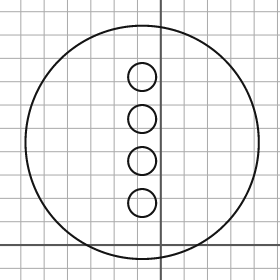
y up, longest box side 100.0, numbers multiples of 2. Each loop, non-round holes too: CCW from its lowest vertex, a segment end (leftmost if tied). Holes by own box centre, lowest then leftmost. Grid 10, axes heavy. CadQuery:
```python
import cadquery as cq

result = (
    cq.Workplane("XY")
    .moveTo(-8.0, 44.0)
    .circle(50.0)
    .moveTo(-8.0, 18.0)
    .circle(6.0)
    .moveTo(-8.0, 36.0)
    .circle(6.0)
    .moveTo(-8.0, 54.0)
    .circle(6.0)
    .moveTo(-8.0, 72.0)
    .circle(6.0)
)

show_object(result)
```